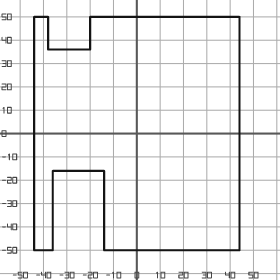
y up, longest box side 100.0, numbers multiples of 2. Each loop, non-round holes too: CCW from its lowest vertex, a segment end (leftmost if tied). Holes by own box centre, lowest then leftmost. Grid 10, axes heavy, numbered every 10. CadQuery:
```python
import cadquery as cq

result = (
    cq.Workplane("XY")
    .moveTo(-44.0, -50.0)
    .lineTo(-36.0, -50.0)
    .lineTo(-36.0, -16.0)
    .lineTo(-14.0, -16.0)
    .lineTo(-14.0, -50.0)
    .lineTo(44.0, -50.0)
    .lineTo(44.0, 50.0)
    .lineTo(-20.0, 50.0)
    .lineTo(-20.0, 36.0)
    .lineTo(-38.0, 36.0)
    .lineTo(-38.0, 50.0)
    .lineTo(-44.0, 50.0)
    .close()
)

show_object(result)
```